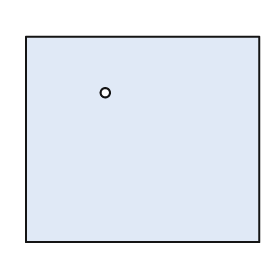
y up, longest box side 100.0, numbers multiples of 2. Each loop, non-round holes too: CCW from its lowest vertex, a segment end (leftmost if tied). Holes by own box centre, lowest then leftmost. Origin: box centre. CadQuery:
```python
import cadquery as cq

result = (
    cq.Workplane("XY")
    .moveTo(-50.0, -44.0)
    .lineTo(50.0, -44.0)
    .lineTo(50.0, 44.0)
    .lineTo(-50.0, 44.0)
    .close()
    .moveTo(-16.0, 20.0)
    .circle(2.0)
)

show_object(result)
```